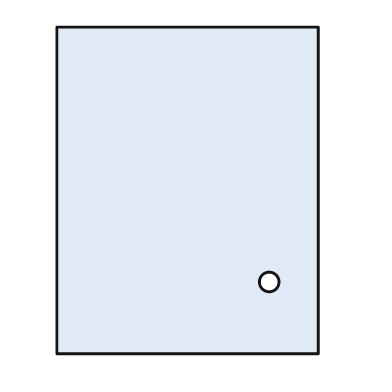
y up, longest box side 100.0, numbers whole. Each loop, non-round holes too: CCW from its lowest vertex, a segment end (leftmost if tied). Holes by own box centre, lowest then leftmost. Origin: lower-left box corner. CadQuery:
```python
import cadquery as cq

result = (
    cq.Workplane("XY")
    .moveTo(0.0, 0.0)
    .lineTo(80.0, 0.0)
    .lineTo(80.0, 100.0)
    .lineTo(0.0, 100.0)
    .close()
    .moveTo(65.0, 22.0)
    .circle(3.0)
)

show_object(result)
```